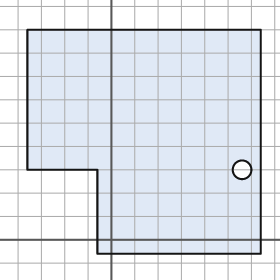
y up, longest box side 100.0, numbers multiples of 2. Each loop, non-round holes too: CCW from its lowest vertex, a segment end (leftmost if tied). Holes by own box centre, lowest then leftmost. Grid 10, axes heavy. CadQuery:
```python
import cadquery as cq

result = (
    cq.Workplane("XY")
    .moveTo(-6.0, -6.0)
    .lineTo(64.0, -6.0)
    .lineTo(64.0, 90.0)
    .lineTo(-36.0, 90.0)
    .lineTo(-36.0, 30.0)
    .lineTo(-6.0, 30.0)
    .close()
    .moveTo(56.0, 30.0)
    .circle(4.0)
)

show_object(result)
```